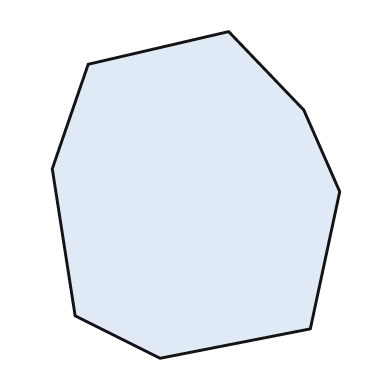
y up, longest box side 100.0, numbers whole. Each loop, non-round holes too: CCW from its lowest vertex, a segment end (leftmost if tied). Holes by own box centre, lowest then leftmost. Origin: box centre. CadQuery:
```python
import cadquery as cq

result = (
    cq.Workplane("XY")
    .moveTo(-11.0, -50.0)
    .lineTo(35.0, -41.0)
    .lineTo(44.0, 1.0)
    .lineTo(33.0, 26.0)
    .lineTo(10.0, 50.0)
    .lineTo(-33.0, 40.0)
    .lineTo(-44.0, 8.0)
    .lineTo(-37.0, -37.0)
    .close()
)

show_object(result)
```